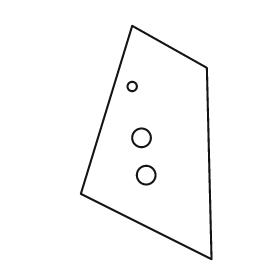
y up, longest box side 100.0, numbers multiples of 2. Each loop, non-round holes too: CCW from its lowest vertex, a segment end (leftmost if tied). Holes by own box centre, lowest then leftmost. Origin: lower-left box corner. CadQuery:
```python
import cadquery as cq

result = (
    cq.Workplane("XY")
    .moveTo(56.0, 0.0)
    .lineTo(54.0, 82.0)
    .lineTo(22.0, 100.0)
    .lineTo(0.0, 28.0)
    .close()
    .moveTo(28.0, 36.0)
    .circle(4.0)
    .moveTo(26.0, 52.0)
    .circle(4.0)
    .moveTo(22.0, 74.0)
    .circle(2.0)
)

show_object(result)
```